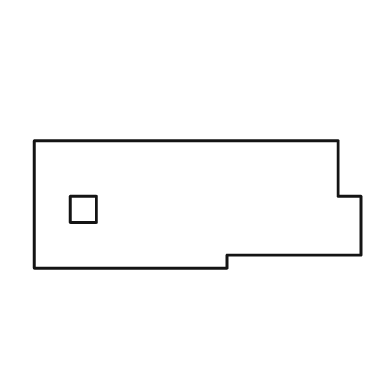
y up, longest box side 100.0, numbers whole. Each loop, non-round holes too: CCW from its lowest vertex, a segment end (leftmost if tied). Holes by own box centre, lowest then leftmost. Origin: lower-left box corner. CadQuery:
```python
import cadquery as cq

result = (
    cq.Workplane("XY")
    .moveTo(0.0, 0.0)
    .lineTo(59.0, 0.0)
    .lineTo(59.0, 4.0)
    .lineTo(100.0, 4.0)
    .lineTo(100.0, 22.0)
    .lineTo(93.0, 22.0)
    .lineTo(93.0, 39.0)
    .lineTo(0.0, 39.0)
    .close()
    .moveTo(11.0, 14.0)
    .lineTo(19.0, 14.0)
    .lineTo(19.0, 22.0)
    .lineTo(11.0, 22.0)
    .close()
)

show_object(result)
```